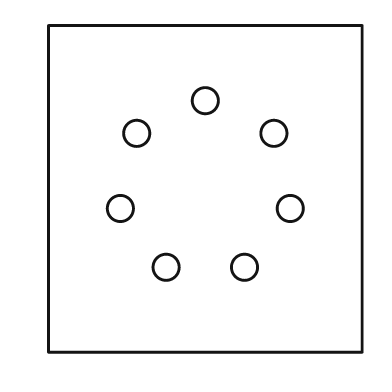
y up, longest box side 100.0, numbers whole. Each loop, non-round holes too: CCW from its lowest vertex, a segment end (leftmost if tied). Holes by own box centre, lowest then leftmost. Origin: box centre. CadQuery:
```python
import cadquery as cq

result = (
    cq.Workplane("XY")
    .moveTo(-48.0, -50.0)
    .lineTo(48.0, -50.0)
    .lineTo(48.0, 50.0)
    .lineTo(-48.0, 50.0)
    .close()
    .moveTo(-12.0, -24.0)
    .circle(4.0)
    .moveTo(12.0, -24.0)
    .circle(4.0)
    .moveTo(-26.0, -6.0)
    .circle(4.0)
    .moveTo(26.0, -6.0)
    .circle(4.0)
    .moveTo(-21.0, 17.0)
    .circle(4.0)
    .moveTo(21.0, 17.0)
    .circle(4.0)
    .moveTo(0.0, 27.0)
    .circle(4.0)
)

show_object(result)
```